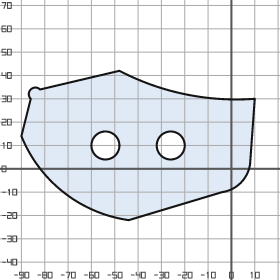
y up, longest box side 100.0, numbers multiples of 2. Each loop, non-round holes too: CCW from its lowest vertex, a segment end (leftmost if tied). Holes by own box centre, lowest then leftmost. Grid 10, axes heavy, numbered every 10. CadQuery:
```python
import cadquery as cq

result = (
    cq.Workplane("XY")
    .moveTo(-44.0, -22.0)
    .lineTo(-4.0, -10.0)
    .threePointArc((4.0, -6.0), (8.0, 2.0))
    .lineTo(10.0, 30.0)
    .threePointArc((-20.0, 32.0), (-48.0, 42.0))
    .lineTo(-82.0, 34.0)
    .threePointArc((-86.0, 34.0), (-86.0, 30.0))
    .lineTo(-90.0, 14.0)
    .threePointArc((-72.0, -10.0), (-44.0, -22.0))
    .close()
    .moveTo(-54.0, 10.0)
    .circle(6.0)
    .moveTo(-26.0, 10.0)
    .circle(6.0)
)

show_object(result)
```